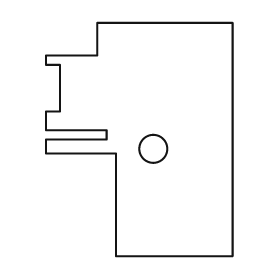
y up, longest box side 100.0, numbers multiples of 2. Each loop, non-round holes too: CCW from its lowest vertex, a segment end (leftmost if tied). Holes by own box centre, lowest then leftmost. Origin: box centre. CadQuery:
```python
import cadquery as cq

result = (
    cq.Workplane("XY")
    .moveTo(-10.0, -50.0)
    .lineTo(40.0, -50.0)
    .lineTo(40.0, 50.0)
    .lineTo(-18.0, 50.0)
    .lineTo(-18.0, 36.0)
    .lineTo(-40.0, 36.0)
    .lineTo(-40.0, 32.0)
    .lineTo(-34.0, 32.0)
    .lineTo(-34.0, 12.0)
    .lineTo(-40.0, 12.0)
    .lineTo(-40.0, 4.0)
    .lineTo(-14.0, 4.0)
    .lineTo(-14.0, 0.0)
    .lineTo(-40.0, 0.0)
    .lineTo(-40.0, -6.0)
    .lineTo(-10.0, -6.0)
    .close()
    .moveTo(6.0, -4.0)
    .circle(6.0)
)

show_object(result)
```